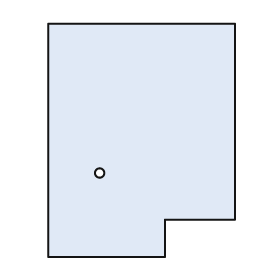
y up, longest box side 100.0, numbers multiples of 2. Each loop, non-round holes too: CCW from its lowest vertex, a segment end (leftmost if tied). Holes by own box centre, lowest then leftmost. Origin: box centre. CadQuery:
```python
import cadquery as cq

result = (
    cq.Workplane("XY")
    .moveTo(-40.0, -50.0)
    .lineTo(10.0, -50.0)
    .lineTo(10.0, -34.0)
    .lineTo(40.0, -34.0)
    .lineTo(40.0, 50.0)
    .lineTo(-40.0, 50.0)
    .close()
    .moveTo(-18.0, -14.0)
    .circle(2.0)
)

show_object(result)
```